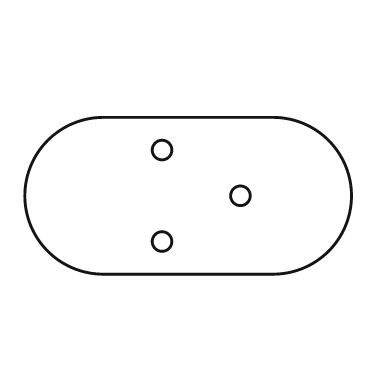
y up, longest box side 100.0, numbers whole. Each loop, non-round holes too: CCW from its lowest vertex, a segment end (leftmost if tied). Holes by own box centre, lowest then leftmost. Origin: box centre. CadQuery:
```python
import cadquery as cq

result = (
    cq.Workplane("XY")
    .moveTo(-26.0, -24.0)
    .lineTo(26.0, -24.0)
    .threePointArc((50.0, 0.0), (26.0, 24.0))
    .lineTo(-26.0, 24.0)
    .threePointArc((-50.0, 0.0), (-26.0, -24.0))
    .close()
    .moveTo(-8.0, -14.0)
    .circle(3.0)
    .moveTo(16.0, 0.0)
    .circle(3.0)
    .moveTo(-8.0, 14.0)
    .circle(3.0)
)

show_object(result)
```